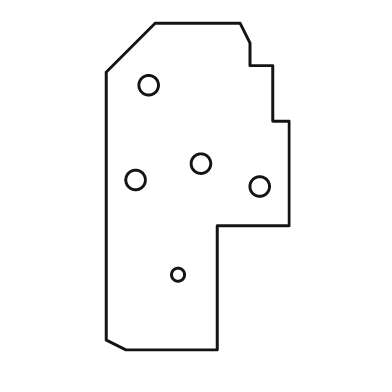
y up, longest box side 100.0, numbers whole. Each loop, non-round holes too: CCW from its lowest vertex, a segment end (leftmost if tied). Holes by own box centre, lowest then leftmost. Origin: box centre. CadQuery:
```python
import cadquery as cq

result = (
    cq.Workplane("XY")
    .moveTo(-22.0, -50.0)
    .lineTo(6.0, -50.0)
    .lineTo(6.0, -12.0)
    .lineTo(28.0, -12.0)
    .lineTo(28.0, 20.0)
    .lineTo(23.0, 20.0)
    .lineTo(23.0, 37.0)
    .lineTo(16.0, 37.0)
    .lineTo(16.0, 44.0)
    .lineTo(13.0, 50.0)
    .lineTo(-13.0, 50.0)
    .lineTo(-28.0, 35.0)
    .lineTo(-28.0, -47.0)
    .close()
    .moveTo(-6.0, -27.0)
    .circle(2.0)
    .moveTo(19.0, 0.0)
    .circle(3.0)
    .moveTo(-19.0, 2.0)
    .circle(3.0)
    .moveTo(1.0, 7.0)
    .circle(3.0)
    .moveTo(-15.0, 31.0)
    .circle(3.0)
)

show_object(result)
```